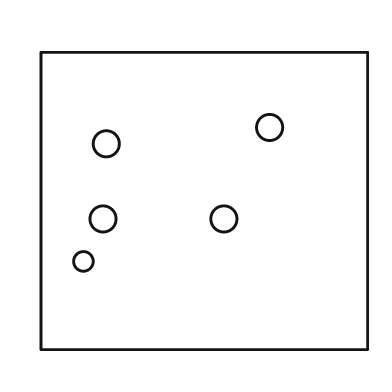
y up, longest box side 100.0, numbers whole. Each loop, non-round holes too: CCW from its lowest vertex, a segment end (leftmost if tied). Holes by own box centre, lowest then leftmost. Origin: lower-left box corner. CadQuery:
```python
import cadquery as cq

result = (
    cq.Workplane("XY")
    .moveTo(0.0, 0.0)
    .lineTo(100.0, 0.0)
    .lineTo(100.0, 91.0)
    .lineTo(0.0, 91.0)
    .close()
    .moveTo(13.0, 27.0)
    .circle(3.0)
    .moveTo(19.0, 40.0)
    .circle(4.0)
    .moveTo(56.0, 40.0)
    .circle(4.0)
    .moveTo(20.0, 63.0)
    .circle(4.0)
    .moveTo(70.0, 68.0)
    .circle(4.0)
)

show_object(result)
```